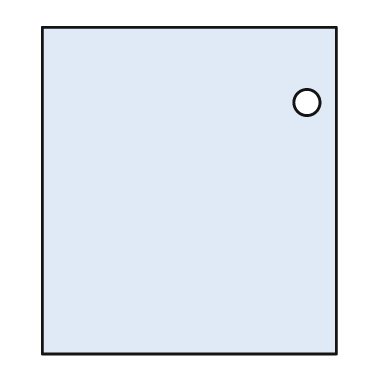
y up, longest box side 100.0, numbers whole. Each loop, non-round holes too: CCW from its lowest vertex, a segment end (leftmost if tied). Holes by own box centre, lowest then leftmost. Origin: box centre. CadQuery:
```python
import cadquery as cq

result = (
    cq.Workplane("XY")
    .moveTo(-45.0, -50.0)
    .lineTo(45.0, -50.0)
    .lineTo(45.0, 50.0)
    .lineTo(-45.0, 50.0)
    .close()
    .moveTo(36.0, 27.0)
    .circle(4.0)
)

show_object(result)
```